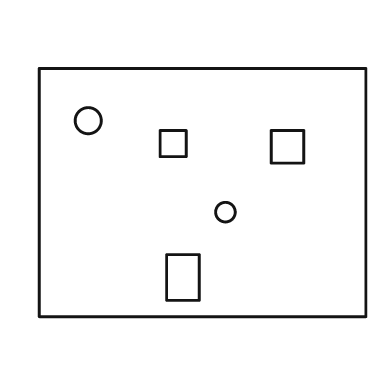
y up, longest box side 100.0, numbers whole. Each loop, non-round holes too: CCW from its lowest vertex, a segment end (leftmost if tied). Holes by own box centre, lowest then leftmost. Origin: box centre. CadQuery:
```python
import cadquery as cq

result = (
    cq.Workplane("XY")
    .moveTo(-50.0, -38.0)
    .lineTo(50.0, -38.0)
    .lineTo(50.0, 38.0)
    .lineTo(-50.0, 38.0)
    .close()
    .moveTo(-11.0, -33.0)
    .lineTo(-1.0, -33.0)
    .lineTo(-1.0, -19.0)
    .lineTo(-11.0, -19.0)
    .close()
    .moveTo(7.0, -6.0)
    .circle(3.0)
    .moveTo(21.0, 9.0)
    .lineTo(31.0, 9.0)
    .lineTo(31.0, 19.0)
    .lineTo(21.0, 19.0)
    .close()
    .moveTo(-13.0, 11.0)
    .lineTo(-5.0, 11.0)
    .lineTo(-5.0, 19.0)
    .lineTo(-13.0, 19.0)
    .close()
    .moveTo(-35.0, 22.0)
    .circle(4.0)
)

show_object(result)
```